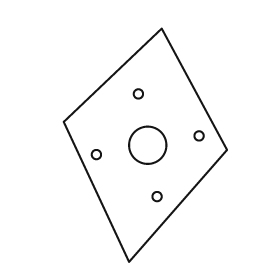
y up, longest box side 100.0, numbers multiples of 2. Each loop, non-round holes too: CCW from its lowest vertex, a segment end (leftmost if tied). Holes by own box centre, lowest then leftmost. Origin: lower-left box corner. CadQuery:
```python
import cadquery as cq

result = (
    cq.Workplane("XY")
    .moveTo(28.0, 0.0)
    .lineTo(70.0, 48.0)
    .lineTo(42.0, 100.0)
    .lineTo(0.0, 60.0)
    .close()
    .moveTo(40.0, 28.0)
    .circle(2.0)
    .moveTo(14.0, 46.0)
    .circle(2.0)
    .moveTo(36.0, 50.0)
    .circle(8.0)
    .moveTo(58.0, 54.0)
    .circle(2.0)
    .moveTo(32.0, 72.0)
    .circle(2.0)
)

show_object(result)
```